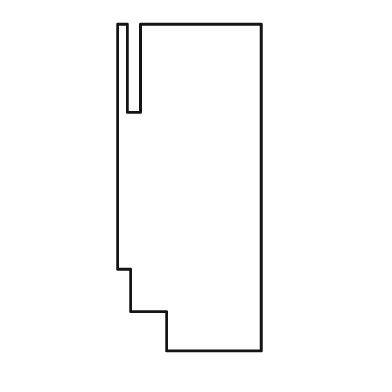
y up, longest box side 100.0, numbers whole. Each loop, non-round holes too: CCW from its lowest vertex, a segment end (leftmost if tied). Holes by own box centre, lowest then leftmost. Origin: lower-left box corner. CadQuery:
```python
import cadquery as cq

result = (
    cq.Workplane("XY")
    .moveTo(15.0, 0.0)
    .lineTo(44.0, 0.0)
    .lineTo(44.0, 100.0)
    .lineTo(7.0, 100.0)
    .lineTo(7.0, 73.0)
    .lineTo(3.0, 73.0)
    .lineTo(3.0, 100.0)
    .lineTo(0.0, 100.0)
    .lineTo(0.0, 25.0)
    .lineTo(4.0, 25.0)
    .lineTo(4.0, 12.0)
    .lineTo(15.0, 12.0)
    .close()
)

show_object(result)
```